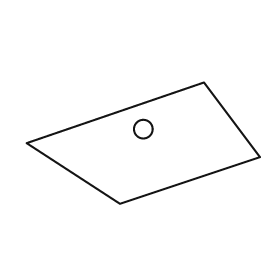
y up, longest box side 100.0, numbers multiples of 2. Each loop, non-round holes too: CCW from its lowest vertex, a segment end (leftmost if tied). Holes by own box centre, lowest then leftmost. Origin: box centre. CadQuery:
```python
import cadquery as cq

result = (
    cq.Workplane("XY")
    .moveTo(-10.0, -26.0)
    .lineTo(50.0, -6.0)
    .lineTo(26.0, 26.0)
    .lineTo(-50.0, 0.0)
    .close()
    .moveTo(0.0, 6.0)
    .circle(4.0)
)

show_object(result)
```